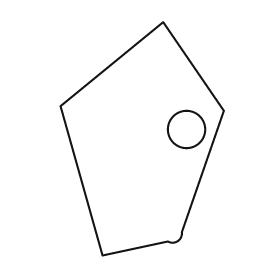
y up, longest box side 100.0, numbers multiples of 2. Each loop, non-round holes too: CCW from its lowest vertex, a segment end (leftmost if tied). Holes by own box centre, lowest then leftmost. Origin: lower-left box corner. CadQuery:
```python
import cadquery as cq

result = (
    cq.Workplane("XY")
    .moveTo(18.0, 0.0)
    .lineTo(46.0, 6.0)
    .threePointArc((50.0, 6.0), (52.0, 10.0))
    .lineTo(70.0, 62.0)
    .lineTo(44.0, 100.0)
    .lineTo(0.0, 64.0)
    .close()
    .moveTo(54.0, 54.0)
    .circle(8.0)
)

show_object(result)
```